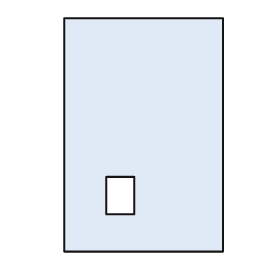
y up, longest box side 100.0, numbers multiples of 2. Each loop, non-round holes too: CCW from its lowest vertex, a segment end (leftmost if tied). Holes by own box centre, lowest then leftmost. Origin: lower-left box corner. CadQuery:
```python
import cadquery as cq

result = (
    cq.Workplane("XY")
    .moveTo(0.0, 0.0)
    .lineTo(68.0, 0.0)
    .lineTo(68.0, 100.0)
    .lineTo(0.0, 100.0)
    .close()
    .moveTo(18.0, 16.0)
    .lineTo(30.0, 16.0)
    .lineTo(30.0, 32.0)
    .lineTo(18.0, 32.0)
    .close()
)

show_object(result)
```